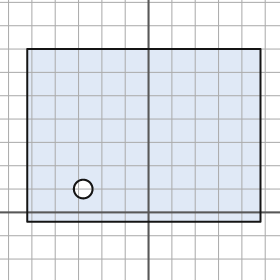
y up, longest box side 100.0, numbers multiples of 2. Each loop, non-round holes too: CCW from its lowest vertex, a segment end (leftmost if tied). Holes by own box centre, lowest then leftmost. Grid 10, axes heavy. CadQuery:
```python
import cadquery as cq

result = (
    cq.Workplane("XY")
    .moveTo(-52.0, -4.0)
    .lineTo(48.0, -4.0)
    .lineTo(48.0, 70.0)
    .lineTo(-52.0, 70.0)
    .close()
    .moveTo(-28.0, 10.0)
    .circle(4.0)
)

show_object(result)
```